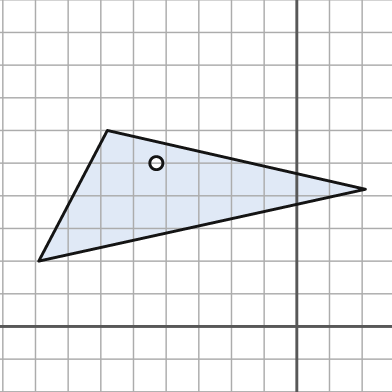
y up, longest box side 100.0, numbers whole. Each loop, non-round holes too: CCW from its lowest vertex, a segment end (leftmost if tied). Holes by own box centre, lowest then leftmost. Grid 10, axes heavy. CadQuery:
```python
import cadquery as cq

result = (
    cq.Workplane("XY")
    .moveTo(-79.0, 20.0)
    .lineTo(21.0, 42.0)
    .lineTo(-58.0, 60.0)
    .close()
    .moveTo(-43.0, 50.0)
    .circle(2.0)
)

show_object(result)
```